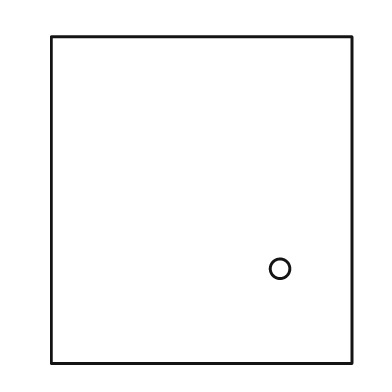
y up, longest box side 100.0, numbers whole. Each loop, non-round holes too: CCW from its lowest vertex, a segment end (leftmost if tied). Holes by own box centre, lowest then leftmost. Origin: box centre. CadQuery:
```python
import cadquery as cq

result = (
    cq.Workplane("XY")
    .moveTo(-46.0, -50.0)
    .lineTo(46.0, -50.0)
    .lineTo(46.0, 50.0)
    .lineTo(-46.0, 50.0)
    .close()
    .moveTo(24.0, -21.0)
    .circle(3.0)
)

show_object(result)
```